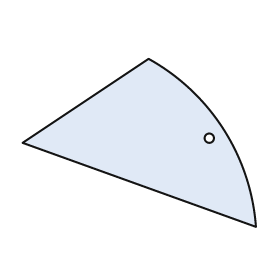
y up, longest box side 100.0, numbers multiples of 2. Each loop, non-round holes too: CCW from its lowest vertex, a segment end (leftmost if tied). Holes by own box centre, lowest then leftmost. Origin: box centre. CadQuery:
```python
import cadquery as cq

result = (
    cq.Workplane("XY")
    .moveTo(50.0, -36.0)
    .threePointArc((36.0, 6.0), (4.0, 36.0))
    .lineTo(-50.0, 0.0)
    .close()
    .moveTo(30.0, 2.0)
    .circle(2.0)
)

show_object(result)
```